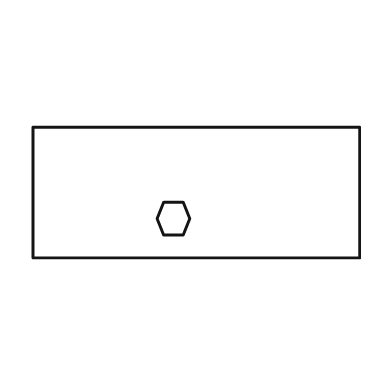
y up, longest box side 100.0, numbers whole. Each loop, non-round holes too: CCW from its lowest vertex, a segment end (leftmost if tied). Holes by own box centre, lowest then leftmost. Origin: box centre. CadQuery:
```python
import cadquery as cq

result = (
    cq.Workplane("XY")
    .moveTo(-50.0, -20.0)
    .lineTo(50.0, -20.0)
    .lineTo(50.0, 20.0)
    .lineTo(-50.0, 20.0)
    .close()
    .moveTo(-10.0, -13.0)
    .lineTo(-4.0, -13.0)
    .lineTo(-2.0, -8.0)
    .lineTo(-4.0, -3.0)
    .lineTo(-10.0, -3.0)
    .lineTo(-12.0, -8.0)
    .close()
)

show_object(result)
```